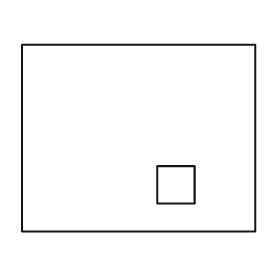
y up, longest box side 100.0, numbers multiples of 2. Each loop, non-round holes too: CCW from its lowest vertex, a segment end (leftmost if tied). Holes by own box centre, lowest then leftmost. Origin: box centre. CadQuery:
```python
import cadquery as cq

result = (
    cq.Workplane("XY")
    .moveTo(-50.0, -40.0)
    .lineTo(50.0, -40.0)
    .lineTo(50.0, 40.0)
    .lineTo(-50.0, 40.0)
    .close()
    .moveTo(8.0, -28.0)
    .lineTo(24.0, -28.0)
    .lineTo(24.0, -12.0)
    .lineTo(8.0, -12.0)
    .close()
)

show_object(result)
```